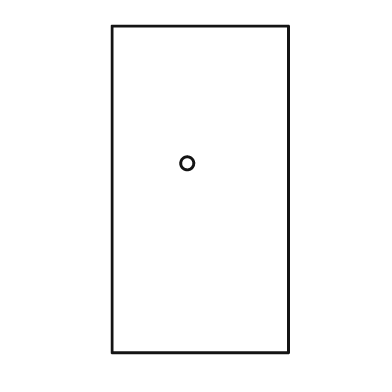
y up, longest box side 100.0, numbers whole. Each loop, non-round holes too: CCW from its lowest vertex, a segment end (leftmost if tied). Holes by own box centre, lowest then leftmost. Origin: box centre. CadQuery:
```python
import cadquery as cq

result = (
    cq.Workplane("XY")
    .moveTo(-27.0, -50.0)
    .lineTo(27.0, -50.0)
    .lineTo(27.0, 50.0)
    .lineTo(-27.0, 50.0)
    .close()
    .moveTo(-4.0, 8.0)
    .circle(2.0)
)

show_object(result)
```